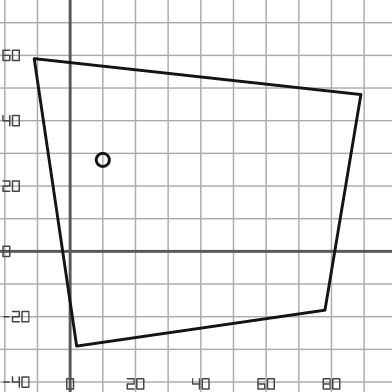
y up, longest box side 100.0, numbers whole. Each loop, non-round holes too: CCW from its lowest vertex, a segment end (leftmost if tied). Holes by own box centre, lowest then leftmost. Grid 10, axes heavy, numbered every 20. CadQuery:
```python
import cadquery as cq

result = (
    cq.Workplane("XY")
    .moveTo(2.0, -29.0)
    .lineTo(78.0, -18.0)
    .lineTo(89.0, 48.0)
    .lineTo(-11.0, 59.0)
    .close()
    .moveTo(10.0, 28.0)
    .circle(2.0)
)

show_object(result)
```